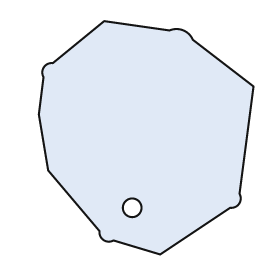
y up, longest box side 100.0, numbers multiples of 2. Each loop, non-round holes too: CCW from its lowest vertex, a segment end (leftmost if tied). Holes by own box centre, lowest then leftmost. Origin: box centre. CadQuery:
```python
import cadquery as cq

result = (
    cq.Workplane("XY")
    .moveTo(6.0, -50.0)
    .lineTo(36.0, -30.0)
    .threePointArc((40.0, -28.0), (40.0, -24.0))
    .lineTo(46.0, 22.0)
    .lineTo(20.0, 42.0)
    .threePointArc((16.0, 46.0), (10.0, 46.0))
    .lineTo(-18.0, 50.0)
    .lineTo(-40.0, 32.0)
    .threePointArc((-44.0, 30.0), (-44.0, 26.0))
    .lineTo(-46.0, 10.0)
    .lineTo(-42.0, -14.0)
    .lineTo(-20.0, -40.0)
    .threePointArc((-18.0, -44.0), (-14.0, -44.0))
    .close()
    .moveTo(-6.0, -30.0)
    .circle(4.0)
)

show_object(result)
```